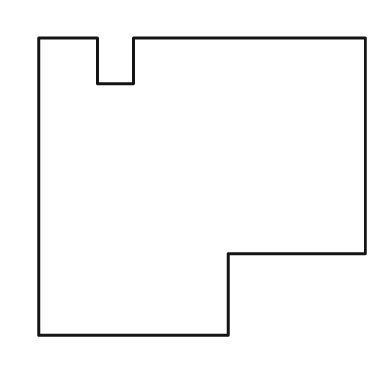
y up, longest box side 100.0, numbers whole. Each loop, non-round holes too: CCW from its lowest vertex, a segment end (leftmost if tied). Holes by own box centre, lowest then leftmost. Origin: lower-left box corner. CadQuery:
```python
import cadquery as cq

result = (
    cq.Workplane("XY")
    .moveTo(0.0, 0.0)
    .lineTo(58.0, 0.0)
    .lineTo(58.0, 25.0)
    .lineTo(100.0, 25.0)
    .lineTo(100.0, 91.0)
    .lineTo(29.0, 91.0)
    .lineTo(29.0, 77.0)
    .lineTo(18.0, 77.0)
    .lineTo(18.0, 91.0)
    .lineTo(0.0, 91.0)
    .close()
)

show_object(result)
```